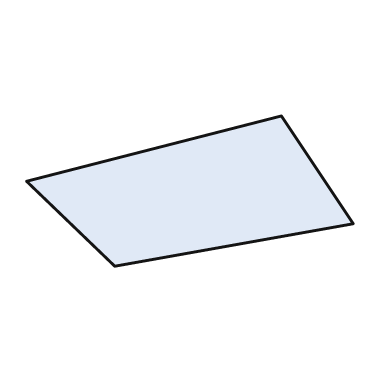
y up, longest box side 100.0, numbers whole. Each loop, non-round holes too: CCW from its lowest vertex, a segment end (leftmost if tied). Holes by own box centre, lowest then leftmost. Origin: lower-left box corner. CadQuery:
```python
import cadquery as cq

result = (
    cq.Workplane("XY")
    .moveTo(27.0, 0.0)
    .lineTo(100.0, 13.0)
    .lineTo(78.0, 46.0)
    .lineTo(0.0, 26.0)
    .close()
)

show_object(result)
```